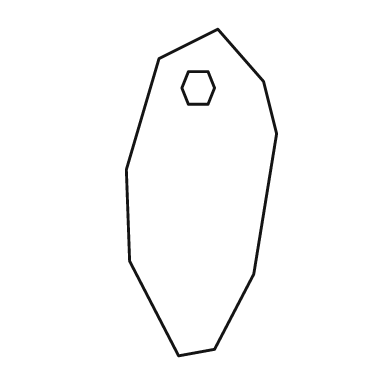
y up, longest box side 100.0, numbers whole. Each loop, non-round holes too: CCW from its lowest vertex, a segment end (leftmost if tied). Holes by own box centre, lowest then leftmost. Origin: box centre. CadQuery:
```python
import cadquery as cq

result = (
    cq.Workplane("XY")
    .moveTo(-7.0, -50.0)
    .lineTo(4.0, -48.0)
    .lineTo(16.0, -25.0)
    .lineTo(23.0, 18.0)
    .lineTo(19.0, 34.0)
    .lineTo(5.0, 50.0)
    .lineTo(-13.0, 41.0)
    .lineTo(-23.0, 7.0)
    .lineTo(-22.0, -21.0)
    .close()
    .moveTo(-4.0, 27.0)
    .lineTo(2.0, 27.0)
    .lineTo(4.0, 32.0)
    .lineTo(2.0, 37.0)
    .lineTo(-4.0, 37.0)
    .lineTo(-6.0, 32.0)
    .close()
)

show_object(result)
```